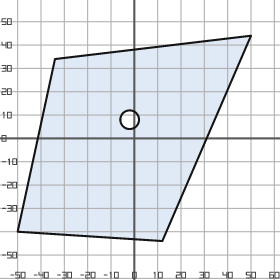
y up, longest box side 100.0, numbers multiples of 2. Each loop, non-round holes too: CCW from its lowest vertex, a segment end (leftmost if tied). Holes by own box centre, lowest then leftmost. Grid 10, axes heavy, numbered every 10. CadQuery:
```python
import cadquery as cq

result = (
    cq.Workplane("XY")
    .moveTo(12.0, -44.0)
    .lineTo(50.0, 44.0)
    .lineTo(-34.0, 34.0)
    .lineTo(-50.0, -40.0)
    .close()
    .moveTo(-2.0, 8.0)
    .circle(4.0)
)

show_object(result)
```